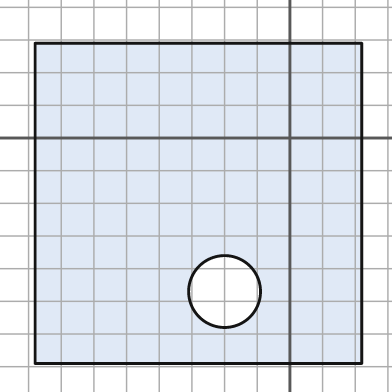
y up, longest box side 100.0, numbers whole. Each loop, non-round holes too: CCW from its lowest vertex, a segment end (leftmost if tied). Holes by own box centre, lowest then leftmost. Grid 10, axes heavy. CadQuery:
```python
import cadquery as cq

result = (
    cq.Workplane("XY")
    .moveTo(-78.0, -69.0)
    .lineTo(22.0, -69.0)
    .lineTo(22.0, 29.0)
    .lineTo(-78.0, 29.0)
    .close()
    .moveTo(-20.0, -47.0)
    .circle(11.0)
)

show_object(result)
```